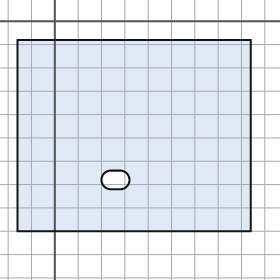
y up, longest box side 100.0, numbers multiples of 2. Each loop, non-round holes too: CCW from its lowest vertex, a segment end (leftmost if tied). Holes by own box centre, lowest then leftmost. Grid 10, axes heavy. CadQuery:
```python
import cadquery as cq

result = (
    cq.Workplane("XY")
    .moveTo(-16.0, -90.0)
    .lineTo(84.0, -90.0)
    .lineTo(84.0, -8.0)
    .lineTo(-16.0, -8.0)
    .close()
    .moveTo(24.0, -72.0)
    .lineTo(28.0, -72.0)
    .threePointArc((32.0, -68.0), (28.0, -64.0))
    .lineTo(24.0, -64.0)
    .threePointArc((20.0, -68.0), (24.0, -72.0))
    .close()
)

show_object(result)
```